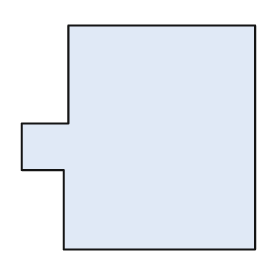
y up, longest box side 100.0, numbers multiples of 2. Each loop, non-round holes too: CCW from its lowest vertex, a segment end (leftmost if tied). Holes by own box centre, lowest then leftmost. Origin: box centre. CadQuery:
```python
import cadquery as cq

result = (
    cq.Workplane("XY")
    .moveTo(-32.0, -48.0)
    .lineTo(50.0, -48.0)
    .lineTo(50.0, 48.0)
    .lineTo(-30.0, 48.0)
    .lineTo(-30.0, 6.0)
    .lineTo(-50.0, 6.0)
    .lineTo(-50.0, -14.0)
    .lineTo(-32.0, -14.0)
    .close()
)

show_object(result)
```